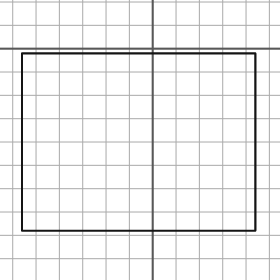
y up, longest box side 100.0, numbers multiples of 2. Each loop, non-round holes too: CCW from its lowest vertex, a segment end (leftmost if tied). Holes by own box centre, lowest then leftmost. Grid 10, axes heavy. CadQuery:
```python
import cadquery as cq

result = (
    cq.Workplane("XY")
    .moveTo(-56.0, -78.0)
    .lineTo(44.0, -78.0)
    .lineTo(44.0, -2.0)
    .lineTo(-56.0, -2.0)
    .close()
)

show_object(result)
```